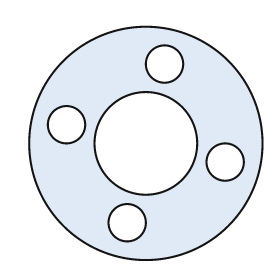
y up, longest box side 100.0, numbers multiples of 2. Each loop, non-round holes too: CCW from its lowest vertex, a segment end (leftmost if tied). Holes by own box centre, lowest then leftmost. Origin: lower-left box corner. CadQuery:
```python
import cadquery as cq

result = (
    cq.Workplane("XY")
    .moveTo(50.0, 50.0)
    .circle(50.0)
    .moveTo(42.0, 16.0)
    .circle(8.0)
    .moveTo(84.0, 42.0)
    .circle(8.0)
    .moveTo(50.0, 50.0)
    .circle(22.0)
    .moveTo(16.0, 58.0)
    .circle(8.0)
    .moveTo(58.0, 84.0)
    .circle(8.0)
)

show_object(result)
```